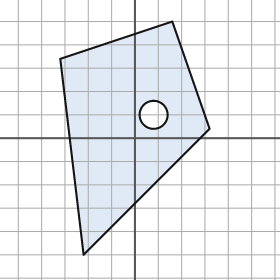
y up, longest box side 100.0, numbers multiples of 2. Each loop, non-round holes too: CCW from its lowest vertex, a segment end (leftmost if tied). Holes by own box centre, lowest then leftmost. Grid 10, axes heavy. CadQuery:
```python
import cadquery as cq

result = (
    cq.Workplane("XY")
    .moveTo(-22.0, -50.0)
    .lineTo(32.0, 4.0)
    .lineTo(16.0, 50.0)
    .lineTo(-32.0, 34.0)
    .close()
    .moveTo(8.0, 10.0)
    .circle(6.0)
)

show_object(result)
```